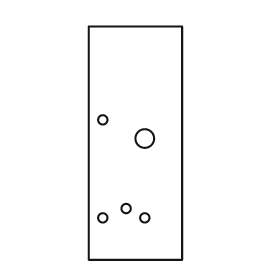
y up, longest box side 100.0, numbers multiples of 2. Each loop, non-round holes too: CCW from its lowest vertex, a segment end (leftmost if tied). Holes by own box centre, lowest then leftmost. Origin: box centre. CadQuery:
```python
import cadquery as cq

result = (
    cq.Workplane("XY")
    .moveTo(-20.0, -50.0)
    .lineTo(20.0, -50.0)
    .lineTo(20.0, 50.0)
    .lineTo(-20.0, 50.0)
    .close()
    .moveTo(-14.0, -32.0)
    .circle(2.0)
    .moveTo(4.0, -32.0)
    .circle(2.0)
    .moveTo(-4.0, -28.0)
    .circle(2.0)
    .moveTo(4.0, 2.0)
    .circle(4.0)
    .moveTo(-14.0, 10.0)
    .circle(2.0)
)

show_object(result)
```